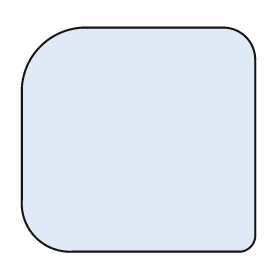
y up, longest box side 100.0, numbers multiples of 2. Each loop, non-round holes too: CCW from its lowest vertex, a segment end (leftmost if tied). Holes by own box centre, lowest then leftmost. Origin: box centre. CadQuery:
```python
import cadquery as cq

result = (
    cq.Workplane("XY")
    .moveTo(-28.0, -48.0)
    .lineTo(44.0, -48.0)
    .threePointArc((48.0, -46.0), (50.0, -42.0))
    .lineTo(50.0, 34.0)
    .threePointArc((46.0, 44.0), (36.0, 48.0))
    .lineTo(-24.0, 48.0)
    .threePointArc((-42.0, 40.0), (-50.0, 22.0))
    .lineTo(-50.0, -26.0)
    .threePointArc((-44.0, -42.0), (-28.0, -48.0))
    .close()
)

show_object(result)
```